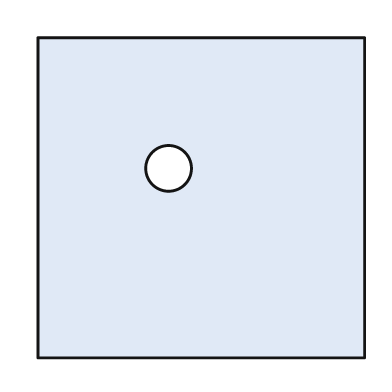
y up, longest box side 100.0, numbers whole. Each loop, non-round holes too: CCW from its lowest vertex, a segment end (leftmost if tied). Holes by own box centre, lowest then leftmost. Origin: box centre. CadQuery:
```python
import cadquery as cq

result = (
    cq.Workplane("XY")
    .moveTo(-50.0, -49.0)
    .lineTo(50.0, -49.0)
    .lineTo(50.0, 49.0)
    .lineTo(-50.0, 49.0)
    .close()
    .moveTo(-10.0, 9.0)
    .circle(7.0)
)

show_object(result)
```